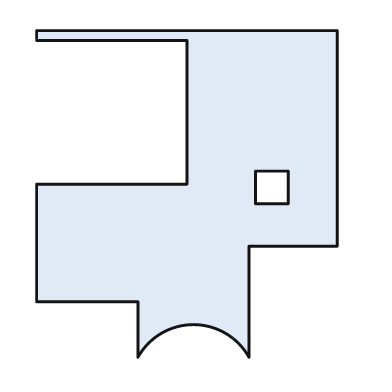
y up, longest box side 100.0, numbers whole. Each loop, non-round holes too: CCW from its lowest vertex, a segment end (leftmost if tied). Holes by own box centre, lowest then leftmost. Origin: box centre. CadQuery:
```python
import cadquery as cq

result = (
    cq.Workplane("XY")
    .moveTo(-15.0, -50.0)
    .threePointArc((2.0, -40.0), (19.0, -50.0))
    .lineTo(19.0, -16.0)
    .lineTo(46.0, -16.0)
    .lineTo(46.0, 50.0)
    .lineTo(-46.0, 50.0)
    .lineTo(-46.0, 47.0)
    .lineTo(0.0, 47.0)
    .lineTo(0.0, 3.0)
    .lineTo(-46.0, 3.0)
    .lineTo(-46.0, -33.0)
    .lineTo(-15.0, -33.0)
    .close()
    .moveTo(21.0, -3.0)
    .lineTo(31.0, -3.0)
    .lineTo(31.0, 7.0)
    .lineTo(21.0, 7.0)
    .close()
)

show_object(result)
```